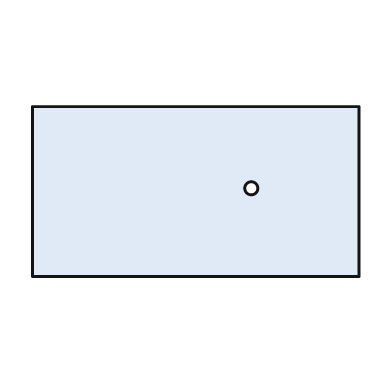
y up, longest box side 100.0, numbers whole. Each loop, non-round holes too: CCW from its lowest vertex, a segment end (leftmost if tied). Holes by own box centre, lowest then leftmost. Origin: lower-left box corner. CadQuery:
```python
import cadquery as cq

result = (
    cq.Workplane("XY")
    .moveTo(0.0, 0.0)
    .lineTo(100.0, 0.0)
    .lineTo(100.0, 52.0)
    .lineTo(0.0, 52.0)
    .close()
    .moveTo(67.0, 27.0)
    .circle(2.0)
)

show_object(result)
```